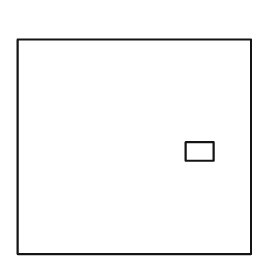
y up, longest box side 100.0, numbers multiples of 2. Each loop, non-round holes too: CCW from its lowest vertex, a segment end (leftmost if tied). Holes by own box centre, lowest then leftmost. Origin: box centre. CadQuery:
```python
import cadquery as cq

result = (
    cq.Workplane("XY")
    .moveTo(-50.0, -46.0)
    .lineTo(50.0, -46.0)
    .lineTo(50.0, 46.0)
    .lineTo(-50.0, 46.0)
    .close()
    .moveTo(22.0, -6.0)
    .lineTo(34.0, -6.0)
    .lineTo(34.0, 2.0)
    .lineTo(22.0, 2.0)
    .close()
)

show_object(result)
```